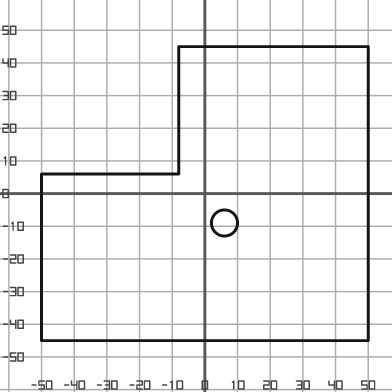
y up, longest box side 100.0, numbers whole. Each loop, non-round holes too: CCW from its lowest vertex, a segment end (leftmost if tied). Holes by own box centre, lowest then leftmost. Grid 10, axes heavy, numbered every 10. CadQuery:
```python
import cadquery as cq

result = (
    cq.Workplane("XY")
    .moveTo(-50.0, -45.0)
    .lineTo(50.0, -45.0)
    .lineTo(50.0, 45.0)
    .lineTo(-8.0, 45.0)
    .lineTo(-8.0, 6.0)
    .lineTo(-50.0, 6.0)
    .close()
    .moveTo(6.0, -9.0)
    .circle(4.0)
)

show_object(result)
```